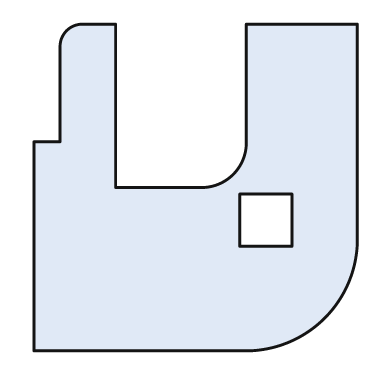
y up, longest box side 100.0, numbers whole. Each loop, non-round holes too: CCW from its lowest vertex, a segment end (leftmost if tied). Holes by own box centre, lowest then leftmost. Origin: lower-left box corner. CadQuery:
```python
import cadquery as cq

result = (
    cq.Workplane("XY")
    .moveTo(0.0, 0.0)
    .lineTo(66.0, 0.0)
    .threePointArc((89.0, 10.0), (99.0, 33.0))
    .lineTo(99.0, 100.0)
    .lineTo(65.0, 100.0)
    .lineTo(65.0, 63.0)
    .threePointArc((61.0, 54.0), (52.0, 50.0))
    .lineTo(25.0, 50.0)
    .lineTo(25.0, 100.0)
    .lineTo(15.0, 100.0)
    .threePointArc((10.0, 98.0), (8.0, 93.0))
    .lineTo(8.0, 64.0)
    .lineTo(0.0, 64.0)
    .close()
    .moveTo(63.0, 32.0)
    .lineTo(79.0, 32.0)
    .lineTo(79.0, 48.0)
    .lineTo(63.0, 48.0)
    .close()
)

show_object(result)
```